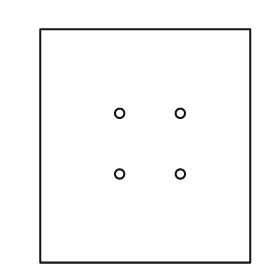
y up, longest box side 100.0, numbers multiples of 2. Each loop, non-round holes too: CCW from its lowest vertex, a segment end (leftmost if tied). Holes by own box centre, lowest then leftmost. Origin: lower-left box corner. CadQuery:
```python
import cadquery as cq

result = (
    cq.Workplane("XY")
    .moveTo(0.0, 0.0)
    .lineTo(90.0, 0.0)
    .lineTo(90.0, 100.0)
    .lineTo(0.0, 100.0)
    .close()
    .moveTo(34.0, 38.0)
    .circle(2.0)
    .moveTo(60.0, 38.0)
    .circle(2.0)
    .moveTo(34.0, 64.0)
    .circle(2.0)
    .moveTo(60.0, 64.0)
    .circle(2.0)
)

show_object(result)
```